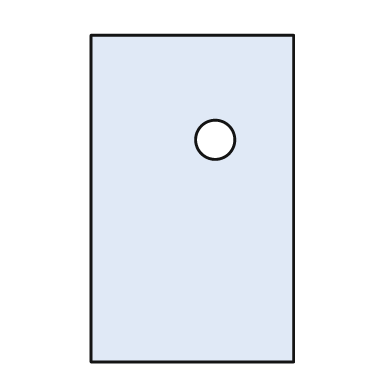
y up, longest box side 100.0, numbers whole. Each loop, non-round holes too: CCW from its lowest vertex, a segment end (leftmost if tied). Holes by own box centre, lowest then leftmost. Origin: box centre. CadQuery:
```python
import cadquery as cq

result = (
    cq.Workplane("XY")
    .moveTo(-31.0, -50.0)
    .lineTo(31.0, -50.0)
    .lineTo(31.0, 50.0)
    .lineTo(-31.0, 50.0)
    .close()
    .moveTo(7.0, 18.0)
    .circle(6.0)
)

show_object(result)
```